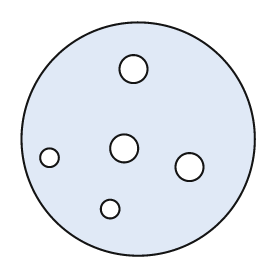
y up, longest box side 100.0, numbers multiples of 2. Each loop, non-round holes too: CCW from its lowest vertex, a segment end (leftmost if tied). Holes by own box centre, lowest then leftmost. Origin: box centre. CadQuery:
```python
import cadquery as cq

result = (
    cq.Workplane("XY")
    .moveTo(0.0, 0.0)
    .circle(50.0)
    .moveTo(-12.0, -30.0)
    .circle(4.0)
    .moveTo(22.0, -12.0)
    .circle(6.0)
    .moveTo(-38.0, -8.0)
    .circle(4.0)
    .moveTo(-6.0, -4.0)
    .circle(6.0)
    .moveTo(-2.0, 30.0)
    .circle(6.0)
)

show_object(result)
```